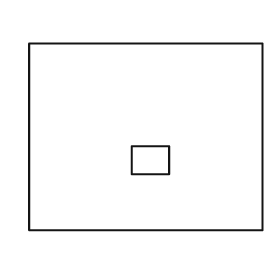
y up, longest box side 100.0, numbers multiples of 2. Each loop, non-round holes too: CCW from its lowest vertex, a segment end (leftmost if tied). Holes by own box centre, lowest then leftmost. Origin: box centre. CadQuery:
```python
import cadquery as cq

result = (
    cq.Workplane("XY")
    .moveTo(-50.0, -40.0)
    .lineTo(50.0, -40.0)
    .lineTo(50.0, 40.0)
    .lineTo(-50.0, 40.0)
    .close()
    .moveTo(-6.0, -16.0)
    .lineTo(10.0, -16.0)
    .lineTo(10.0, -4.0)
    .lineTo(-6.0, -4.0)
    .close()
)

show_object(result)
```